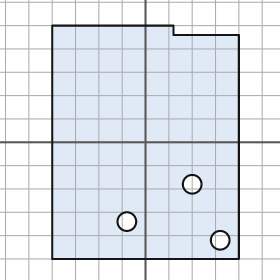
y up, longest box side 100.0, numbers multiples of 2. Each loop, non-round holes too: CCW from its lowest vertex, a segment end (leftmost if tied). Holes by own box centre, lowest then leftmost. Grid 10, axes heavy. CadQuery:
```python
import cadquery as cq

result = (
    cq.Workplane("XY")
    .moveTo(-40.0, -50.0)
    .lineTo(40.0, -50.0)
    .lineTo(40.0, 46.0)
    .lineTo(12.0, 46.0)
    .lineTo(12.0, 50.0)
    .lineTo(-40.0, 50.0)
    .close()
    .moveTo(32.0, -42.0)
    .circle(4.0)
    .moveTo(-8.0, -34.0)
    .circle(4.0)
    .moveTo(20.0, -18.0)
    .circle(4.0)
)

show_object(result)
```